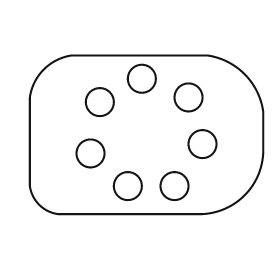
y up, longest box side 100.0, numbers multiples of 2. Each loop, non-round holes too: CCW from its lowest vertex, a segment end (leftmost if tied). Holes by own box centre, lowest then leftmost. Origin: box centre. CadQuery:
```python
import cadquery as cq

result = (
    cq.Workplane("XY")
    .moveTo(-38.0, -34.0)
    .lineTo(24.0, -34.0)
    .threePointArc((42.0, -26.0), (50.0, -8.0))
    .lineTo(50.0, 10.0)
    .threePointArc((42.0, 26.0), (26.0, 34.0))
    .lineTo(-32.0, 34.0)
    .threePointArc((-44.0, 28.0), (-50.0, 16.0))
    .lineTo(-50.0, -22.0)
    .threePointArc((-46.0, -30.0), (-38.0, -34.0))
    .close()
    .moveTo(-8.0, -22.0)
    .circle(6.0)
    .moveTo(12.0, -22.0)
    .circle(6.0)
    .moveTo(-24.0, -8.0)
    .circle(6.0)
    .moveTo(24.0, -4.0)
    .circle(6.0)
    .moveTo(-20.0, 14.0)
    .circle(6.0)
    .moveTo(18.0, 16.0)
    .circle(6.0)
    .moveTo(-2.0, 24.0)
    .circle(6.0)
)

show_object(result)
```